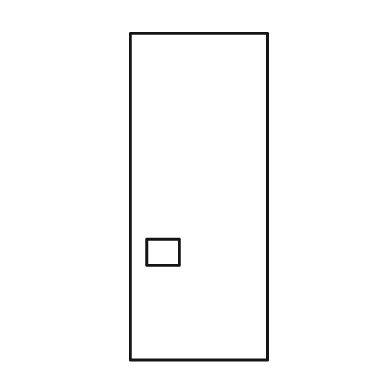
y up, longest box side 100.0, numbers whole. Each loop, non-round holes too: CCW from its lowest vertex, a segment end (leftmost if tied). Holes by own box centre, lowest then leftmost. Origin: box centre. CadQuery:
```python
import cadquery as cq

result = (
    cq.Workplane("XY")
    .moveTo(-21.0, -50.0)
    .lineTo(21.0, -50.0)
    .lineTo(21.0, 50.0)
    .lineTo(-21.0, 50.0)
    .close()
    .moveTo(-16.0, -21.0)
    .lineTo(-6.0, -21.0)
    .lineTo(-6.0, -13.0)
    .lineTo(-16.0, -13.0)
    .close()
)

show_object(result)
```